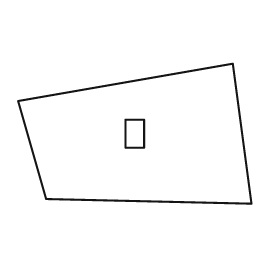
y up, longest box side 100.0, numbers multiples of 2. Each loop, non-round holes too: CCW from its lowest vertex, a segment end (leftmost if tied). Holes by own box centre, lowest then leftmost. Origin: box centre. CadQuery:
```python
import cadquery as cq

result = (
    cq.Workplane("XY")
    .moveTo(50.0, -30.0)
    .lineTo(42.0, 30.0)
    .lineTo(-50.0, 14.0)
    .lineTo(-38.0, -28.0)
    .close()
    .moveTo(-4.0, -6.0)
    .lineTo(4.0, -6.0)
    .lineTo(4.0, 6.0)
    .lineTo(-4.0, 6.0)
    .close()
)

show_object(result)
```